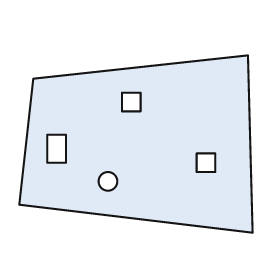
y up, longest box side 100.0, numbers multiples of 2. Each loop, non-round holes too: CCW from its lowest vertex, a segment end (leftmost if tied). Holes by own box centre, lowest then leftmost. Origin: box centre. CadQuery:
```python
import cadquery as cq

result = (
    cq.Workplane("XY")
    .moveTo(50.0, -38.0)
    .lineTo(48.0, 38.0)
    .lineTo(-44.0, 28.0)
    .lineTo(-50.0, -26.0)
    .close()
    .moveTo(-12.0, -16.0)
    .circle(4.0)
    .moveTo(26.0, -12.0)
    .lineTo(34.0, -12.0)
    .lineTo(34.0, -4.0)
    .lineTo(26.0, -4.0)
    .close()
    .moveTo(-38.0, -8.0)
    .lineTo(-30.0, -8.0)
    .lineTo(-30.0, 4.0)
    .lineTo(-38.0, 4.0)
    .close()
    .moveTo(-6.0, 14.0)
    .lineTo(2.0, 14.0)
    .lineTo(2.0, 22.0)
    .lineTo(-6.0, 22.0)
    .close()
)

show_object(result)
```